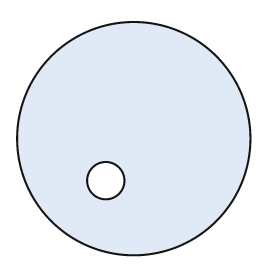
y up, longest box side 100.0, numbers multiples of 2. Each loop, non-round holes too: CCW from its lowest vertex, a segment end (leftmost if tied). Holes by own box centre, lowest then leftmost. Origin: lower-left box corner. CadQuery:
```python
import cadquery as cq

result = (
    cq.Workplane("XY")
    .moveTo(50.0, 50.0)
    .circle(50.0)
    .moveTo(38.0, 32.0)
    .circle(8.0)
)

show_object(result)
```